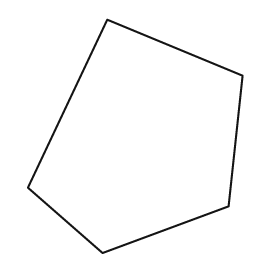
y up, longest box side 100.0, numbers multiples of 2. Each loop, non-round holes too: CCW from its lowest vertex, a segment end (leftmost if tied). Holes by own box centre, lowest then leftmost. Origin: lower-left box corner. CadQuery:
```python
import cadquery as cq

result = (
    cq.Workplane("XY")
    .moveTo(32.0, 0.0)
    .lineTo(86.0, 20.0)
    .lineTo(92.0, 76.0)
    .lineTo(34.0, 100.0)
    .lineTo(0.0, 28.0)
    .close()
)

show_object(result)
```